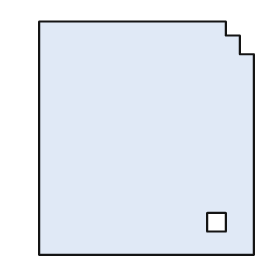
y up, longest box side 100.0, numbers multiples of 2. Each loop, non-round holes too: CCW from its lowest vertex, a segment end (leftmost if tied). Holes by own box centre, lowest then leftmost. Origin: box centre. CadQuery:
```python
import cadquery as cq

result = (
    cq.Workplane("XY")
    .moveTo(-46.0, -50.0)
    .lineTo(46.0, -50.0)
    .lineTo(46.0, 36.0)
    .lineTo(40.0, 36.0)
    .lineTo(40.0, 44.0)
    .lineTo(34.0, 44.0)
    .lineTo(34.0, 50.0)
    .lineTo(-46.0, 50.0)
    .close()
    .moveTo(26.0, -40.0)
    .lineTo(34.0, -40.0)
    .lineTo(34.0, -32.0)
    .lineTo(26.0, -32.0)
    .close()
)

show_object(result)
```